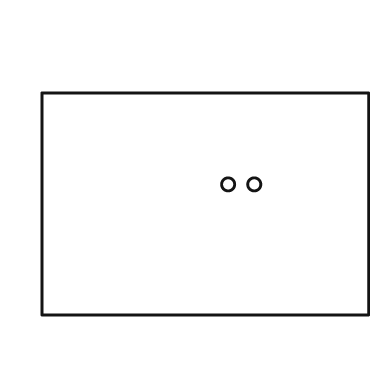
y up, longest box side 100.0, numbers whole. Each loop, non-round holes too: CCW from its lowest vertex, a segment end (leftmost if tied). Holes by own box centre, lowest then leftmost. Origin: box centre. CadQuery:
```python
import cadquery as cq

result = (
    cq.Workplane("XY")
    .moveTo(-50.0, -34.0)
    .lineTo(50.0, -34.0)
    .lineTo(50.0, 34.0)
    .lineTo(-50.0, 34.0)
    .close()
    .moveTo(7.0, 6.0)
    .circle(2.0)
    .moveTo(15.0, 6.0)
    .circle(2.0)
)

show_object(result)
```